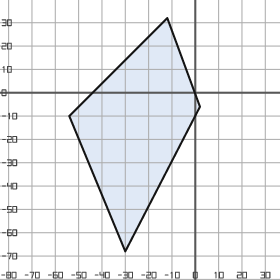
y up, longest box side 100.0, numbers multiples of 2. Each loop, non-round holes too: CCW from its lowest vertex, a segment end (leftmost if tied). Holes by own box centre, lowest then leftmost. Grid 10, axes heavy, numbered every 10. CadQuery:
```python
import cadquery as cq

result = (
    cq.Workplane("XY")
    .moveTo(-30.0, -68.0)
    .lineTo(2.0, -6.0)
    .lineTo(-12.0, 32.0)
    .lineTo(-54.0, -10.0)
    .close()
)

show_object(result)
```